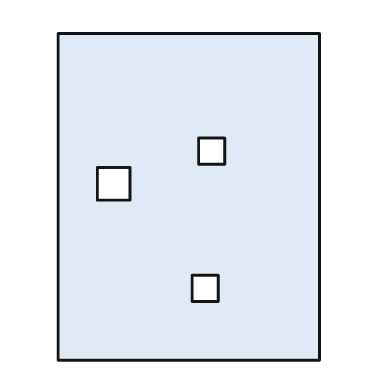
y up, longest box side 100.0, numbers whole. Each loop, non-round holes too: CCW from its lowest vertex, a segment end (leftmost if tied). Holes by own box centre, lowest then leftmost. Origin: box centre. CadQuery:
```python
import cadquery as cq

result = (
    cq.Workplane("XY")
    .moveTo(-40.0, -50.0)
    .lineTo(40.0, -50.0)
    .lineTo(40.0, 50.0)
    .lineTo(-40.0, 50.0)
    .close()
    .moveTo(1.0, -32.0)
    .lineTo(9.0, -32.0)
    .lineTo(9.0, -24.0)
    .lineTo(1.0, -24.0)
    .close()
    .moveTo(-28.0, -1.0)
    .lineTo(-18.0, -1.0)
    .lineTo(-18.0, 9.0)
    .lineTo(-28.0, 9.0)
    .close()
    .moveTo(3.0, 10.0)
    .lineTo(11.0, 10.0)
    .lineTo(11.0, 18.0)
    .lineTo(3.0, 18.0)
    .close()
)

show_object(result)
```